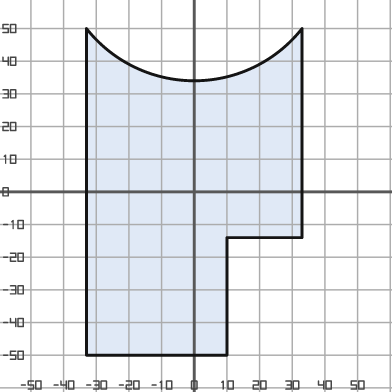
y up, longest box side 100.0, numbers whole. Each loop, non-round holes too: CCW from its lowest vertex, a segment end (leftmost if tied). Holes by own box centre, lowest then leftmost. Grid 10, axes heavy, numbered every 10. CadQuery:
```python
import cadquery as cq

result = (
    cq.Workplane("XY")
    .moveTo(-33.0, -50.0)
    .lineTo(10.0, -50.0)
    .lineTo(10.0, -14.0)
    .lineTo(33.0, -14.0)
    .lineTo(33.0, 50.0)
    .threePointArc((0.0, 34.0), (-33.0, 50.0))
    .close()
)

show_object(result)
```